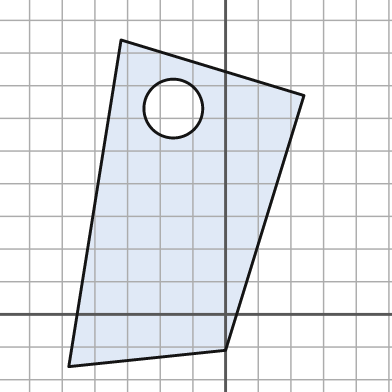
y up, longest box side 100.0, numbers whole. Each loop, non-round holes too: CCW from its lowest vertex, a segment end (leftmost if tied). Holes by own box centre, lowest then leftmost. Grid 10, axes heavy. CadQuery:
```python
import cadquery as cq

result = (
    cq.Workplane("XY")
    .moveTo(-48.0, -16.0)
    .lineTo(0.0, -11.0)
    .lineTo(24.0, 67.0)
    .lineTo(-32.0, 84.0)
    .close()
    .moveTo(-16.0, 63.0)
    .circle(9.0)
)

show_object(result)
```